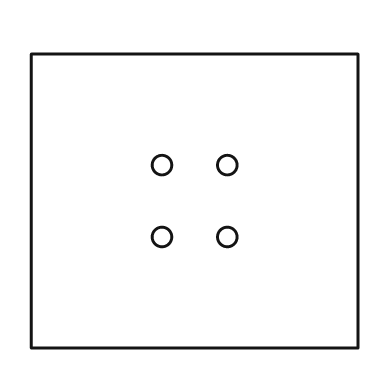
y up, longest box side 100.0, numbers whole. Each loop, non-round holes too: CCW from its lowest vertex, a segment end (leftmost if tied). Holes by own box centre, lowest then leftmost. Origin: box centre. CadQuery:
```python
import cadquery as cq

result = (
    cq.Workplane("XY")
    .moveTo(-50.0, -45.0)
    .lineTo(50.0, -45.0)
    .lineTo(50.0, 45.0)
    .lineTo(-50.0, 45.0)
    .close()
    .moveTo(-10.0, -11.0)
    .circle(3.0)
    .moveTo(10.0, -11.0)
    .circle(3.0)
    .moveTo(-10.0, 11.0)
    .circle(3.0)
    .moveTo(10.0, 11.0)
    .circle(3.0)
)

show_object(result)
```